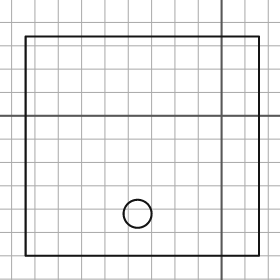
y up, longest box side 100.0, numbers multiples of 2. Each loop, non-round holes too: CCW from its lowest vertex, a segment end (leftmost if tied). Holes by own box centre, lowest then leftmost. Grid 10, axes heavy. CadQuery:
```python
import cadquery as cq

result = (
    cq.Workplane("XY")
    .moveTo(-84.0, -60.0)
    .lineTo(16.0, -60.0)
    .lineTo(16.0, 34.0)
    .lineTo(-84.0, 34.0)
    .close()
    .moveTo(-36.0, -42.0)
    .circle(6.0)
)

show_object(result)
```